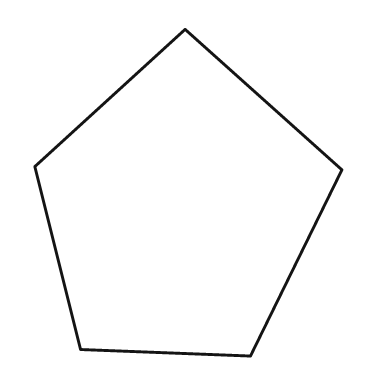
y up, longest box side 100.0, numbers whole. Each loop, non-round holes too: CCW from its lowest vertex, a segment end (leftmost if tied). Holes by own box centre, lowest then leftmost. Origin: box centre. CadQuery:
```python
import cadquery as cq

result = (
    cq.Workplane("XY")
    .moveTo(19.0, -50.0)
    .lineTo(47.0, 7.0)
    .lineTo(-1.0, 50.0)
    .lineTo(-47.0, 8.0)
    .lineTo(-33.0, -48.0)
    .close()
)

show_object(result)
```